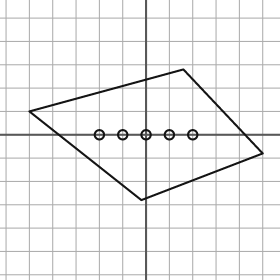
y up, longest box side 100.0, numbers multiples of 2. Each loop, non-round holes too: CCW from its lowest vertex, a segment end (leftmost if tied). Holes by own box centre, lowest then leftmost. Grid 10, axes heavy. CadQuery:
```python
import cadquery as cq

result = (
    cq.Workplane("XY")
    .moveTo(-2.0, -28.0)
    .lineTo(50.0, -8.0)
    .lineTo(16.0, 28.0)
    .lineTo(-50.0, 10.0)
    .close()
    .moveTo(-20.0, 0.0)
    .circle(2.0)
    .moveTo(-10.0, 0.0)
    .circle(2.0)
    .moveTo(0.0, 0.0)
    .circle(2.0)
    .moveTo(10.0, 0.0)
    .circle(2.0)
    .moveTo(20.0, 0.0)
    .circle(2.0)
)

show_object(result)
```